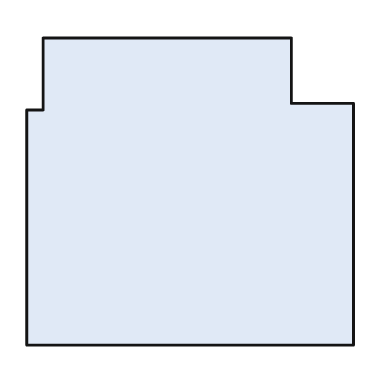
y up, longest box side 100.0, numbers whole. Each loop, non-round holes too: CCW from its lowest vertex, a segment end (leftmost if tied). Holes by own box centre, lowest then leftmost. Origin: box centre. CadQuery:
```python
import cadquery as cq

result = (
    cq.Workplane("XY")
    .moveTo(-50.0, -47.0)
    .lineTo(50.0, -47.0)
    .lineTo(50.0, 27.0)
    .lineTo(31.0, 27.0)
    .lineTo(31.0, 47.0)
    .lineTo(-45.0, 47.0)
    .lineTo(-45.0, 25.0)
    .lineTo(-50.0, 25.0)
    .close()
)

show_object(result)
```